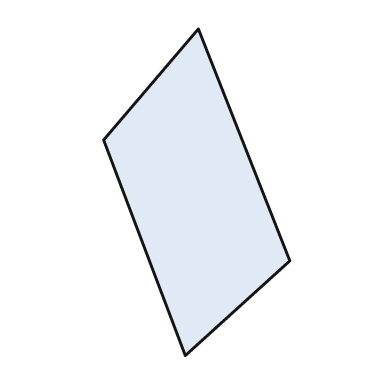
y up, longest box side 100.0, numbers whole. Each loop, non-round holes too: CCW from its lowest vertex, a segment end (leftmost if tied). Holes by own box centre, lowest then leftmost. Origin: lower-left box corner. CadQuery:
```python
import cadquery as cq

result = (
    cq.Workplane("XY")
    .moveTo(25.0, 0.0)
    .lineTo(57.0, 29.0)
    .lineTo(29.0, 100.0)
    .lineTo(0.0, 66.0)
    .close()
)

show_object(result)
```